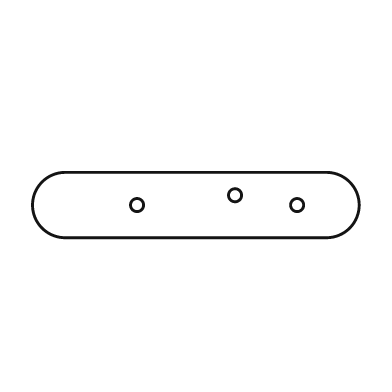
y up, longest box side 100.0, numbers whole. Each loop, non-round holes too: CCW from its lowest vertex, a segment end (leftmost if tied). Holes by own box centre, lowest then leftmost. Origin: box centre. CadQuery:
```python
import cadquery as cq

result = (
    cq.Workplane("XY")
    .moveTo(-40.0, -10.0)
    .lineTo(40.0, -10.0)
    .threePointArc((50.0, 0.0), (40.0, 10.0))
    .lineTo(-40.0, 10.0)
    .threePointArc((-50.0, 0.0), (-40.0, -10.0))
    .close()
    .moveTo(-18.0, 0.0)
    .circle(2.0)
    .moveTo(31.0, 0.0)
    .circle(2.0)
    .moveTo(12.0, 3.0)
    .circle(2.0)
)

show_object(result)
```